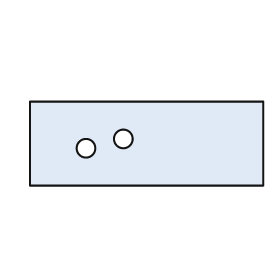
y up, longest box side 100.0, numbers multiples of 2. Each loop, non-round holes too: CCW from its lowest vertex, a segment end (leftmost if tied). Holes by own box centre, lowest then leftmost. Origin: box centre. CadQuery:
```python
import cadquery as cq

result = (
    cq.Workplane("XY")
    .moveTo(-50.0, -18.0)
    .lineTo(50.0, -18.0)
    .lineTo(50.0, 18.0)
    .lineTo(-50.0, 18.0)
    .close()
    .moveTo(-26.0, -2.0)
    .circle(4.0)
    .moveTo(-10.0, 2.0)
    .circle(4.0)
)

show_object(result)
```